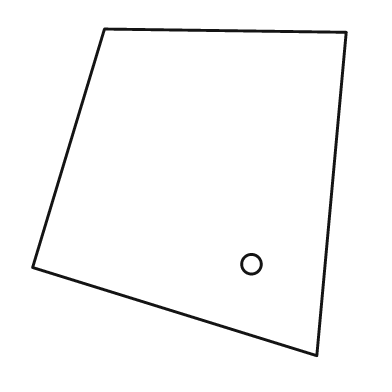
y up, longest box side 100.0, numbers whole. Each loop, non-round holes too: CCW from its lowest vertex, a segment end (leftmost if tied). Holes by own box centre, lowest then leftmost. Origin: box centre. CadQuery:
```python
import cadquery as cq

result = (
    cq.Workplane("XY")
    .moveTo(39.0, -50.0)
    .lineTo(48.0, 49.0)
    .lineTo(-26.0, 50.0)
    .lineTo(-48.0, -23.0)
    .close()
    .moveTo(19.0, -22.0)
    .circle(3.0)
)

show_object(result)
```